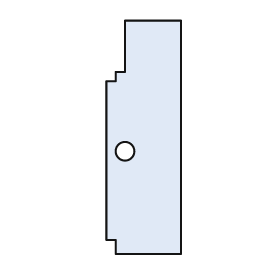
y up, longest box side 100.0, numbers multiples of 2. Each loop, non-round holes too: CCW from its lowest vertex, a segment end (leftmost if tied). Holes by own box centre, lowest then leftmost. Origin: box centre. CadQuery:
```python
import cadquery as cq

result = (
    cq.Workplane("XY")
    .moveTo(-12.0, -50.0)
    .lineTo(16.0, -50.0)
    .lineTo(16.0, 50.0)
    .lineTo(-8.0, 50.0)
    .lineTo(-8.0, 28.0)
    .lineTo(-12.0, 28.0)
    .lineTo(-12.0, 24.0)
    .lineTo(-16.0, 24.0)
    .lineTo(-16.0, -44.0)
    .lineTo(-12.0, -44.0)
    .close()
    .moveTo(-8.0, -6.0)
    .circle(4.0)
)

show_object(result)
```